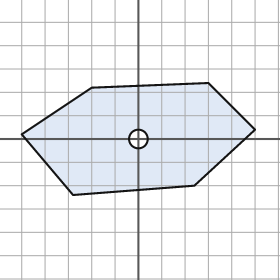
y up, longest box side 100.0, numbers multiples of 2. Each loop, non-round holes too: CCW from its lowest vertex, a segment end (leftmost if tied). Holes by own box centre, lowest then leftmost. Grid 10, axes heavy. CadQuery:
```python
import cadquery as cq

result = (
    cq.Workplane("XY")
    .moveTo(-28.0, -24.0)
    .lineTo(24.0, -20.0)
    .lineTo(50.0, 4.0)
    .lineTo(30.0, 24.0)
    .lineTo(-20.0, 22.0)
    .lineTo(-50.0, 2.0)
    .close()
    .moveTo(0.0, 0.0)
    .circle(4.0)
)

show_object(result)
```